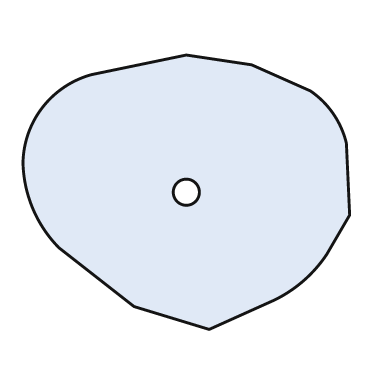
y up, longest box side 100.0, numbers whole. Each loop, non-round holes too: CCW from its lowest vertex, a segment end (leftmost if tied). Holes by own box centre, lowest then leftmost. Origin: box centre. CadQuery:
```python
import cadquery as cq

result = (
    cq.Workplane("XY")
    .moveTo(7.0, -42.0)
    .lineTo(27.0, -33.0)
    .threePointArc((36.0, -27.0), (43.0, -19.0))
    .lineTo(50.0, -7.0)
    .lineTo(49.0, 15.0)
    .threePointArc((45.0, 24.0), (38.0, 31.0))
    .lineTo(20.0, 39.0)
    .lineTo(0.0, 42.0)
    .lineTo(-29.0, 36.0)
    .threePointArc((-44.0, 26.0), (-50.0, 9.0))
    .threePointArc((-47.0, -5.0), (-39.0, -17.0))
    .lineTo(-16.0, -35.0)
    .close()
    .moveTo(0.0, 0.0)
    .circle(4.0)
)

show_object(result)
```